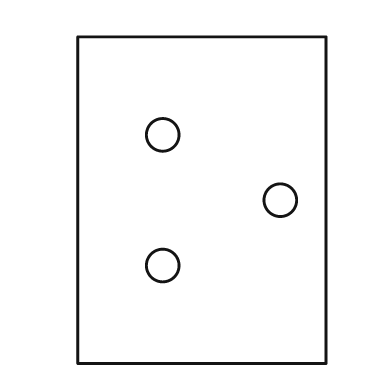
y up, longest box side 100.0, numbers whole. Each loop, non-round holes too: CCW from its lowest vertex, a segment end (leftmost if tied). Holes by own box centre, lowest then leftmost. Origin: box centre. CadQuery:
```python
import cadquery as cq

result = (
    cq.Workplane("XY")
    .moveTo(-38.0, -50.0)
    .lineTo(38.0, -50.0)
    .lineTo(38.0, 50.0)
    .lineTo(-38.0, 50.0)
    .close()
    .moveTo(-12.0, -20.0)
    .circle(5.0)
    .moveTo(24.0, 0.0)
    .circle(5.0)
    .moveTo(-12.0, 20.0)
    .circle(5.0)
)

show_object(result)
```